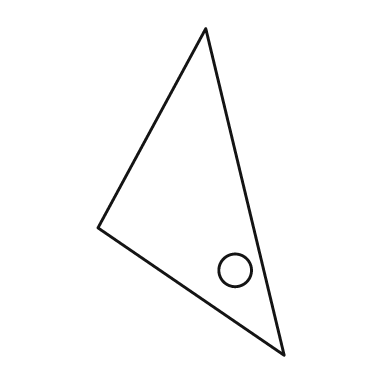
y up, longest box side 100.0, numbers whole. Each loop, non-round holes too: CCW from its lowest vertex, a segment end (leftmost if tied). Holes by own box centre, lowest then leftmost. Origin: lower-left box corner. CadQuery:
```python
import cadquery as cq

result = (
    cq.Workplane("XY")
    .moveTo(57.0, 0.0)
    .lineTo(33.0, 100.0)
    .lineTo(0.0, 39.0)
    .close()
    .moveTo(42.0, 26.0)
    .circle(5.0)
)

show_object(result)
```